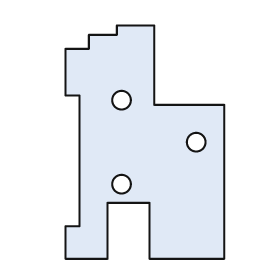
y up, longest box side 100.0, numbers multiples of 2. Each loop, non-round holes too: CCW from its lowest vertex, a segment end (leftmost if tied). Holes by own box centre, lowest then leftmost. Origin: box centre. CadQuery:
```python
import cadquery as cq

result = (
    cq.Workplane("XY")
    .moveTo(-34.0, -50.0)
    .lineTo(-16.0, -50.0)
    .lineTo(-16.0, -26.0)
    .lineTo(2.0, -26.0)
    .lineTo(2.0, -50.0)
    .lineTo(34.0, -50.0)
    .lineTo(34.0, 16.0)
    .lineTo(4.0, 16.0)
    .lineTo(4.0, 50.0)
    .lineTo(-12.0, 50.0)
    .lineTo(-12.0, 46.0)
    .lineTo(-24.0, 46.0)
    .lineTo(-24.0, 40.0)
    .lineTo(-34.0, 40.0)
    .lineTo(-34.0, 20.0)
    .lineTo(-28.0, 20.0)
    .lineTo(-28.0, -36.0)
    .lineTo(-34.0, -36.0)
    .close()
    .moveTo(-10.0, -18.0)
    .circle(4.0)
    .moveTo(22.0, 0.0)
    .circle(4.0)
    .moveTo(-10.0, 18.0)
    .circle(4.0)
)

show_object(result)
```